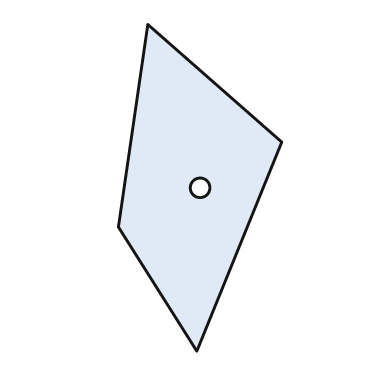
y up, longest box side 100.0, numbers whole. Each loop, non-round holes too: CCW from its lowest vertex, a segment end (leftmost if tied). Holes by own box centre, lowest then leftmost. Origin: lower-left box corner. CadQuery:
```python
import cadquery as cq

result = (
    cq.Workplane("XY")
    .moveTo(24.0, 0.0)
    .lineTo(50.0, 64.0)
    .lineTo(9.0, 100.0)
    .lineTo(0.0, 38.0)
    .close()
    .moveTo(25.0, 50.0)
    .circle(3.0)
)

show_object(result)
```